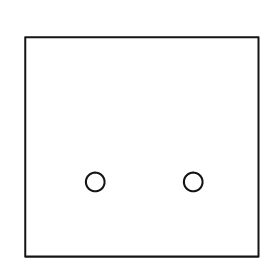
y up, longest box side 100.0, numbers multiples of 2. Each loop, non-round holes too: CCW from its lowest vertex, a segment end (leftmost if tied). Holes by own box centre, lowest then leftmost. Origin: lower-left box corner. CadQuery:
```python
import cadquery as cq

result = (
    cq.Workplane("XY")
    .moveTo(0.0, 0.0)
    .lineTo(100.0, 0.0)
    .lineTo(100.0, 94.0)
    .lineTo(0.0, 94.0)
    .close()
    .moveTo(30.0, 32.0)
    .circle(4.0)
    .moveTo(72.0, 32.0)
    .circle(4.0)
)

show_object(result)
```